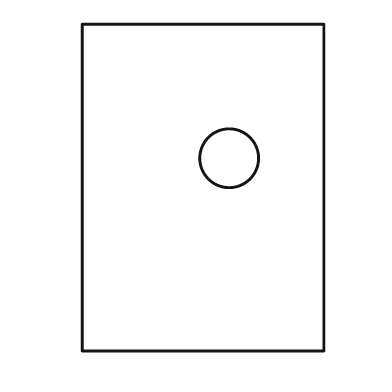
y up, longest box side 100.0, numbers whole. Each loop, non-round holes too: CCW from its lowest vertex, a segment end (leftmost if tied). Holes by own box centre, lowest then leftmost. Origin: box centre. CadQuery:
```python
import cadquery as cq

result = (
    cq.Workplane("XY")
    .moveTo(-37.0, -50.0)
    .lineTo(37.0, -50.0)
    .lineTo(37.0, 50.0)
    .lineTo(-37.0, 50.0)
    .close()
    .moveTo(8.0, 9.0)
    .circle(9.0)
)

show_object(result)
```